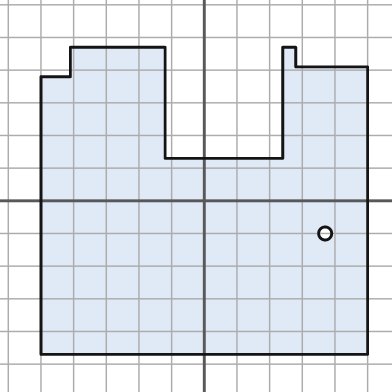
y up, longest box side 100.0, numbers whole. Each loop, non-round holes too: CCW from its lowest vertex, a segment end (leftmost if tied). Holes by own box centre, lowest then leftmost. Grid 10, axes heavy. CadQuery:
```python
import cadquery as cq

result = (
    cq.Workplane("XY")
    .moveTo(-50.0, -47.0)
    .lineTo(50.0, -47.0)
    .lineTo(50.0, 41.0)
    .lineTo(28.0, 41.0)
    .lineTo(28.0, 47.0)
    .lineTo(24.0, 47.0)
    .lineTo(24.0, 13.0)
    .lineTo(-12.0, 13.0)
    .lineTo(-12.0, 47.0)
    .lineTo(-41.0, 47.0)
    .lineTo(-41.0, 38.0)
    .lineTo(-50.0, 38.0)
    .close()
    .moveTo(37.0, -10.0)
    .circle(2.0)
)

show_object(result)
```